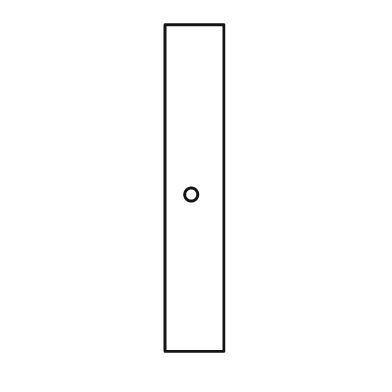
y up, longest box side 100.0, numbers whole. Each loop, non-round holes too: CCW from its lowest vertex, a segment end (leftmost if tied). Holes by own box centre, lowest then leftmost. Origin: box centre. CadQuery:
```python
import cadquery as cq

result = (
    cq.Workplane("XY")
    .moveTo(-9.0, -50.0)
    .lineTo(9.0, -50.0)
    .lineTo(9.0, 50.0)
    .lineTo(-9.0, 50.0)
    .close()
    .moveTo(-1.0, -2.0)
    .circle(2.0)
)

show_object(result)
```